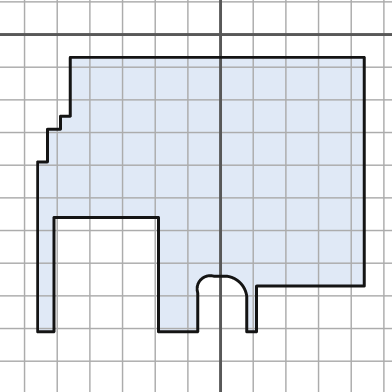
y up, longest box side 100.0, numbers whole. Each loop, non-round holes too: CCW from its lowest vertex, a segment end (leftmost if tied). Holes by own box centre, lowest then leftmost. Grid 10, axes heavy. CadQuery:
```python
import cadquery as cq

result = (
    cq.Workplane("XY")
    .moveTo(-56.0, -91.0)
    .lineTo(-51.0, -91.0)
    .lineTo(-51.0, -56.0)
    .lineTo(-19.0, -56.0)
    .lineTo(-19.0, -91.0)
    .lineTo(-7.0, -91.0)
    .lineTo(-7.0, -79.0)
    .threePointArc((-6.0, -75.0), (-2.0, -74.0))
    .lineTo(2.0, -74.0)
    .threePointArc((6.0, -76.0), (8.0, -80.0))
    .lineTo(8.0, -91.0)
    .lineTo(11.0, -91.0)
    .lineTo(11.0, -77.0)
    .lineTo(44.0, -77.0)
    .lineTo(44.0, -7.0)
    .lineTo(-46.0, -7.0)
    .lineTo(-46.0, -25.0)
    .lineTo(-49.0, -25.0)
    .lineTo(-49.0, -29.0)
    .lineTo(-53.0, -29.0)
    .lineTo(-53.0, -39.0)
    .lineTo(-56.0, -39.0)
    .close()
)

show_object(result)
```